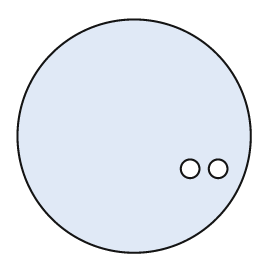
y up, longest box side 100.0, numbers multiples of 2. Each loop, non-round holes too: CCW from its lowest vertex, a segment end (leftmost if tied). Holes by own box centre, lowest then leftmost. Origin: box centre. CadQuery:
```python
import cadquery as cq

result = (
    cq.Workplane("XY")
    .moveTo(0.0, 0.0)
    .circle(50.0)
    .moveTo(24.0, -14.0)
    .circle(4.0)
    .moveTo(36.0, -14.0)
    .circle(4.0)
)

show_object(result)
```